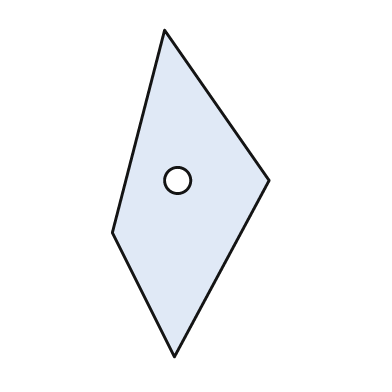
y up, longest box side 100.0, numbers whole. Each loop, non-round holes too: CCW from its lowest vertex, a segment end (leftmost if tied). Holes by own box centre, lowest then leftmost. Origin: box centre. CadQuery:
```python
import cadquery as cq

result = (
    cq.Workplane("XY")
    .moveTo(-5.0, -50.0)
    .lineTo(24.0, 4.0)
    .lineTo(-8.0, 50.0)
    .lineTo(-24.0, -12.0)
    .close()
    .moveTo(-4.0, 4.0)
    .circle(4.0)
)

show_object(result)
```